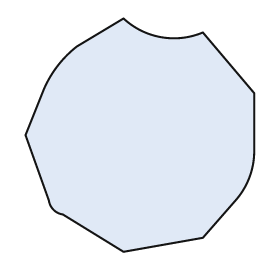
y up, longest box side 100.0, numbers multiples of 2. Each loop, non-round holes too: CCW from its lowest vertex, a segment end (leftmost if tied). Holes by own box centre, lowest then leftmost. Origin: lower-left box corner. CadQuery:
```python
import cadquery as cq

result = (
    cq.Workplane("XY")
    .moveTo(42.0, 0.0)
    .lineTo(76.0, 6.0)
    .lineTo(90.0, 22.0)
    .threePointArc((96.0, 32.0), (98.0, 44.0))
    .lineTo(98.0, 68.0)
    .lineTo(76.0, 94.0)
    .threePointArc((58.0, 92.0), (42.0, 100.0))
    .lineTo(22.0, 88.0)
    .threePointArc((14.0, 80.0), (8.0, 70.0))
    .lineTo(0.0, 50.0)
    .lineTo(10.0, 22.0)
    .threePointArc((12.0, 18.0), (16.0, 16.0))
    .close()
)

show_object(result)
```